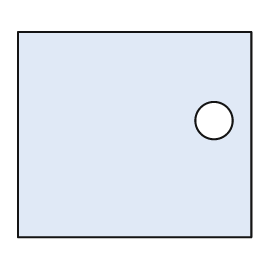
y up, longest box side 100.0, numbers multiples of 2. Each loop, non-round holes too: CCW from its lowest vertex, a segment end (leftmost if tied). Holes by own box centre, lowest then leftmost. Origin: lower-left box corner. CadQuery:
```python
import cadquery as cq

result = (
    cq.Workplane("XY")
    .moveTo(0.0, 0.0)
    .lineTo(100.0, 0.0)
    .lineTo(100.0, 88.0)
    .lineTo(0.0, 88.0)
    .close()
    .moveTo(84.0, 50.0)
    .circle(8.0)
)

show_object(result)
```